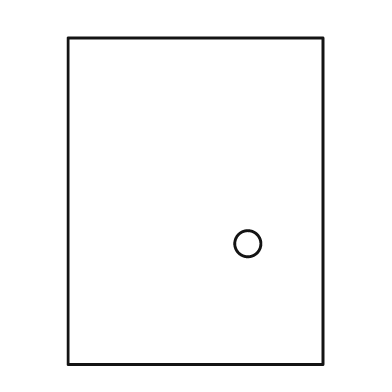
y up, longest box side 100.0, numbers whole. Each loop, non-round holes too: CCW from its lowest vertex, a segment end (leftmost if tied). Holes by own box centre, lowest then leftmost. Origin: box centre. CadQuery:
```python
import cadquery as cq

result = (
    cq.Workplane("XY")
    .moveTo(-39.0, -50.0)
    .lineTo(39.0, -50.0)
    .lineTo(39.0, 50.0)
    .lineTo(-39.0, 50.0)
    .close()
    .moveTo(16.0, -13.0)
    .circle(4.0)
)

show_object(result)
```